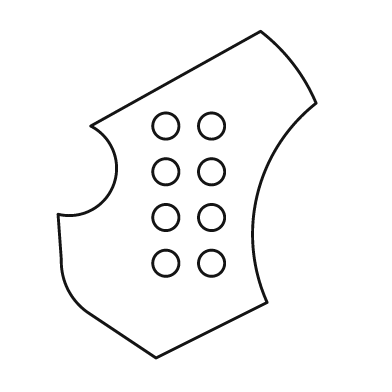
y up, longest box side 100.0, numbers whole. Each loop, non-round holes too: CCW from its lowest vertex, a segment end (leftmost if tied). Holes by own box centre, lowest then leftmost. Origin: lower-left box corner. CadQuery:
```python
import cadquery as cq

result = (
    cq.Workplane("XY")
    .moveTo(30.0, 0.0)
    .lineTo(64.0, 17.0)
    .threePointArc((61.0, 50.0), (79.0, 78.0))
    .threePointArc((72.0, 90.0), (62.0, 100.0))
    .lineTo(10.0, 71.0)
    .threePointArc((17.0, 53.0), (0.0, 44.0))
    .lineTo(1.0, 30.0)
    .threePointArc((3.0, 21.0), (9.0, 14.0))
    .close()
    .moveTo(33.0, 29.0)
    .circle(4.0)
    .moveTo(47.0, 29.0)
    .circle(4.0)
    .moveTo(33.0, 43.0)
    .circle(4.0)
    .moveTo(47.0, 43.0)
    .circle(4.0)
    .moveTo(33.0, 57.0)
    .circle(4.0)
    .moveTo(47.0, 57.0)
    .circle(4.0)
    .moveTo(33.0, 71.0)
    .circle(4.0)
    .moveTo(47.0, 71.0)
    .circle(4.0)
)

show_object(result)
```